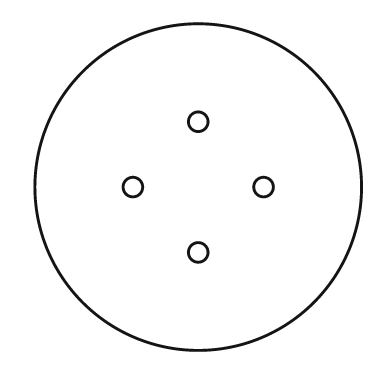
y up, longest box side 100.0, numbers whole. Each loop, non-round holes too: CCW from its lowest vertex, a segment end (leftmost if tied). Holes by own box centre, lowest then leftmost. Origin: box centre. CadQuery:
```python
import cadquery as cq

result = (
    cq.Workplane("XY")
    .moveTo(0.0, 0.0)
    .circle(50.0)
    .moveTo(0.0, -20.0)
    .circle(3.0)
    .moveTo(-20.0, 0.0)
    .circle(3.0)
    .moveTo(20.0, 0.0)
    .circle(3.0)
    .moveTo(0.0, 20.0)
    .circle(3.0)
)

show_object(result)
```